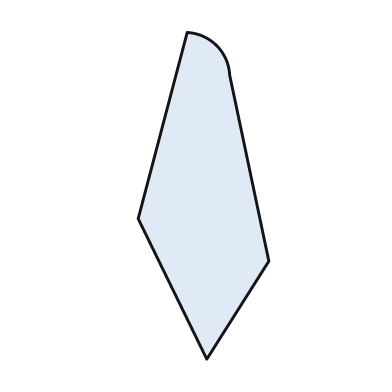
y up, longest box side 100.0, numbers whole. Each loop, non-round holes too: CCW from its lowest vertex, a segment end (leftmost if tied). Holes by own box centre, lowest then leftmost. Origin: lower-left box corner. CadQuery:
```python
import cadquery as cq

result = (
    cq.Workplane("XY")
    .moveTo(21.0, 0.0)
    .lineTo(40.0, 30.0)
    .lineTo(28.0, 87.0)
    .threePointArc((24.0, 96.0), (15.0, 100.0))
    .lineTo(0.0, 43.0)
    .close()
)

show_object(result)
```